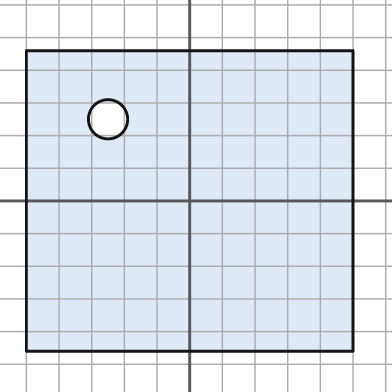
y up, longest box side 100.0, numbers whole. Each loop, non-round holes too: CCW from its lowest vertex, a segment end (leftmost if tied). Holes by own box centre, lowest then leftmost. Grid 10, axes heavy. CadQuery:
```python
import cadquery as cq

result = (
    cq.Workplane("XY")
    .moveTo(-50.0, -46.0)
    .lineTo(50.0, -46.0)
    .lineTo(50.0, 46.0)
    .lineTo(-50.0, 46.0)
    .close()
    .moveTo(-25.0, 25.0)
    .circle(6.0)
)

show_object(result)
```